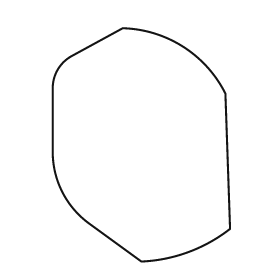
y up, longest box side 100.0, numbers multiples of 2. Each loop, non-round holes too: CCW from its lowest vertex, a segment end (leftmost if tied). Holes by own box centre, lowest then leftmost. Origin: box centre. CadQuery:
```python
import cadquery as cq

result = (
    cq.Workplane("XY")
    .moveTo(0.0, -50.0)
    .threePointArc((20.0, -46.0), (38.0, -36.0))
    .lineTo(36.0, 22.0)
    .threePointArc((18.0, 42.0), (-8.0, 50.0))
    .lineTo(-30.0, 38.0)
    .threePointArc((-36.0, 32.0), (-38.0, 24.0))
    .lineTo(-38.0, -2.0)
    .threePointArc((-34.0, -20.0), (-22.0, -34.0))
    .close()
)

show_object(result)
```